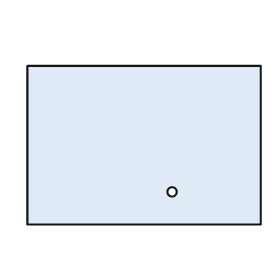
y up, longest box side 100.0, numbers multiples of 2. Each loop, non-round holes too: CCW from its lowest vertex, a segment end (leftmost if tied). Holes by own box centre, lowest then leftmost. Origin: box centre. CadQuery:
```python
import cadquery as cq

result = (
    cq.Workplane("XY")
    .moveTo(-50.0, -34.0)
    .lineTo(50.0, -34.0)
    .lineTo(50.0, 34.0)
    .lineTo(-50.0, 34.0)
    .close()
    .moveTo(12.0, -20.0)
    .circle(2.0)
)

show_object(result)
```